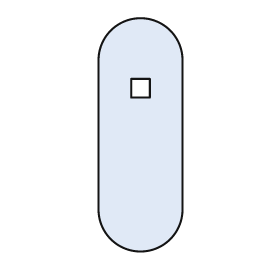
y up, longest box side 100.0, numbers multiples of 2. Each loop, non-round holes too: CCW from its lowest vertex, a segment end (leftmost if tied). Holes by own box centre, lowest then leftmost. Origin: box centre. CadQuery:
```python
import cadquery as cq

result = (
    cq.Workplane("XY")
    .moveTo(-18.0, -32.0)
    .threePointArc((0.0, -50.0), (18.0, -32.0))
    .lineTo(18.0, 32.0)
    .threePointArc((0.0, 50.0), (-18.0, 32.0))
    .close()
    .moveTo(-4.0, 16.0)
    .lineTo(4.0, 16.0)
    .lineTo(4.0, 24.0)
    .lineTo(-4.0, 24.0)
    .close()
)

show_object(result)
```